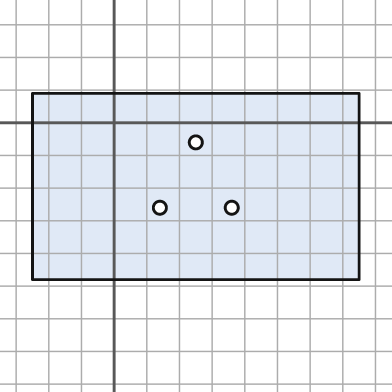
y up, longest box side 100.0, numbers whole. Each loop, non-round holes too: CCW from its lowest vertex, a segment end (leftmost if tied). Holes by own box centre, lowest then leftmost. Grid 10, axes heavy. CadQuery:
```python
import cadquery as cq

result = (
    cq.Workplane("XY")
    .moveTo(-25.0, -48.0)
    .lineTo(75.0, -48.0)
    .lineTo(75.0, 9.0)
    .lineTo(-25.0, 9.0)
    .close()
    .moveTo(14.0, -26.0)
    .circle(2.0)
    .moveTo(36.0, -26.0)
    .circle(2.0)
    .moveTo(25.0, -6.0)
    .circle(2.0)
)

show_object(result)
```